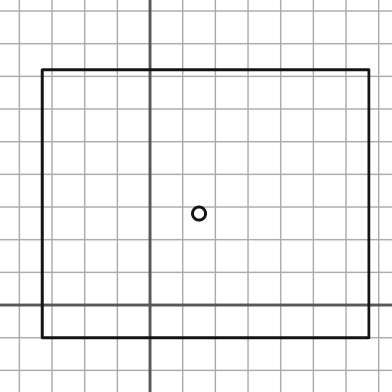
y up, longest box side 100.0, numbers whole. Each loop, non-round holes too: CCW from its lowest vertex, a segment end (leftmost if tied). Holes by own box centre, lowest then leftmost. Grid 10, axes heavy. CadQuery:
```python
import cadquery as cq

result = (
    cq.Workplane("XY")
    .moveTo(-33.0, -10.0)
    .lineTo(67.0, -10.0)
    .lineTo(67.0, 72.0)
    .lineTo(-33.0, 72.0)
    .close()
    .moveTo(15.0, 28.0)
    .circle(2.0)
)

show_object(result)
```